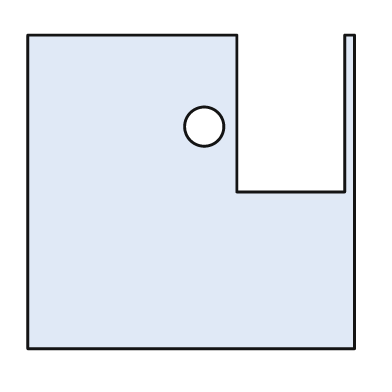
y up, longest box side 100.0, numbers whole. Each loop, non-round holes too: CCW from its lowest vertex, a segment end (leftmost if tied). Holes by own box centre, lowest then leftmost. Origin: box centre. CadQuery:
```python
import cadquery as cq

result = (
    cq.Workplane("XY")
    .moveTo(-50.0, -48.0)
    .lineTo(50.0, -48.0)
    .lineTo(50.0, 48.0)
    .lineTo(47.0, 48.0)
    .lineTo(47.0, 0.0)
    .lineTo(14.0, 0.0)
    .lineTo(14.0, 48.0)
    .lineTo(-50.0, 48.0)
    .close()
    .moveTo(4.0, 20.0)
    .circle(6.0)
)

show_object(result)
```